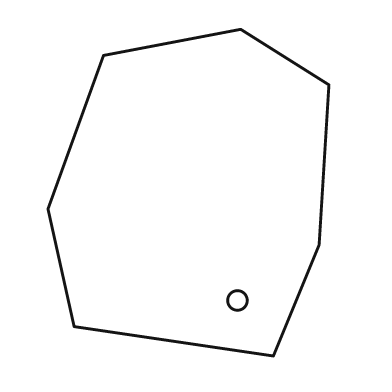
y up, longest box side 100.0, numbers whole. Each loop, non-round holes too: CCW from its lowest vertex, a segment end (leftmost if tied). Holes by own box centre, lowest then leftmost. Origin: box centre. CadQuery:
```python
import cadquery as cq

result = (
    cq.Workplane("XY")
    .moveTo(26.0, -50.0)
    .lineTo(40.0, -16.0)
    .lineTo(43.0, 33.0)
    .lineTo(16.0, 50.0)
    .lineTo(-26.0, 42.0)
    .lineTo(-43.0, -5.0)
    .lineTo(-35.0, -41.0)
    .close()
    .moveTo(15.0, -33.0)
    .circle(3.0)
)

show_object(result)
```